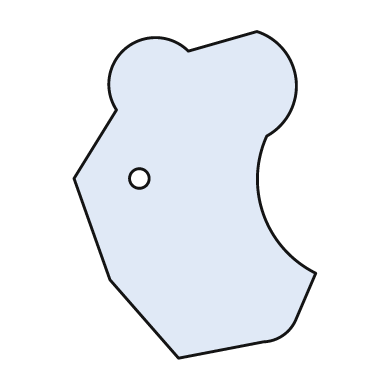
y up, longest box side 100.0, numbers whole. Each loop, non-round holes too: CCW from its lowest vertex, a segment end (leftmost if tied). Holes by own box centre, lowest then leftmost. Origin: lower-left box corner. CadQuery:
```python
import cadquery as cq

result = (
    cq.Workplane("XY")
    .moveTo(32.0, 0.0)
    .lineTo(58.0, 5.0)
    .threePointArc((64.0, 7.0), (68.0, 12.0))
    .lineTo(74.0, 26.0)
    .threePointArc((58.0, 44.0), (59.0, 68.0))
    .threePointArc((68.0, 85.0), (56.0, 100.0))
    .lineTo(35.0, 94.0)
    .threePointArc((16.0, 95.0), (13.0, 76.0))
    .lineTo(0.0, 55.0)
    .lineTo(11.0, 24.0)
    .close()
    .moveTo(20.0, 55.0)
    .circle(3.0)
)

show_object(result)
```